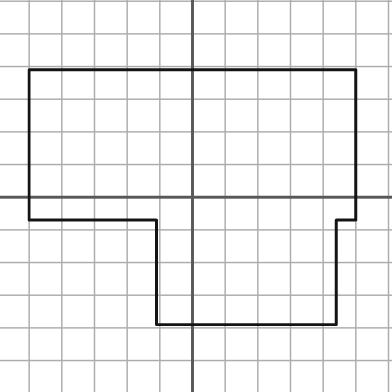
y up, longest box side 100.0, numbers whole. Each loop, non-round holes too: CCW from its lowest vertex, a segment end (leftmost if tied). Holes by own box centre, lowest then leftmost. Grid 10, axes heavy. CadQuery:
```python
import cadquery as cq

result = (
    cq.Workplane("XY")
    .moveTo(-11.0, -39.0)
    .lineTo(44.0, -39.0)
    .lineTo(44.0, -7.0)
    .lineTo(50.0, -7.0)
    .lineTo(50.0, 39.0)
    .lineTo(-50.0, 39.0)
    .lineTo(-50.0, -7.0)
    .lineTo(-11.0, -7.0)
    .close()
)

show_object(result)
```